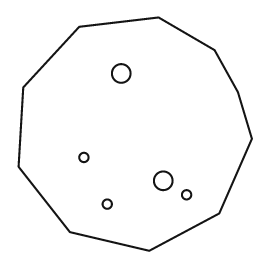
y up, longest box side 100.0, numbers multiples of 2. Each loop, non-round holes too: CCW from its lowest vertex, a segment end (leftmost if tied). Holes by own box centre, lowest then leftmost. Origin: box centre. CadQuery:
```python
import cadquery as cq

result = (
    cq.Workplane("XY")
    .moveTo(6.0, -50.0)
    .lineTo(36.0, -34.0)
    .lineTo(50.0, -2.0)
    .lineTo(44.0, 18.0)
    .lineTo(34.0, 36.0)
    .lineTo(10.0, 50.0)
    .lineTo(-24.0, 46.0)
    .lineTo(-48.0, 20.0)
    .lineTo(-50.0, -14.0)
    .lineTo(-28.0, -42.0)
    .close()
    .moveTo(-12.0, -30.0)
    .circle(2.0)
    .moveTo(22.0, -26.0)
    .circle(2.0)
    .moveTo(12.0, -20.0)
    .circle(4.0)
    .moveTo(-22.0, -10.0)
    .circle(2.0)
    .moveTo(-6.0, 26.0)
    .circle(4.0)
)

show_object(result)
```